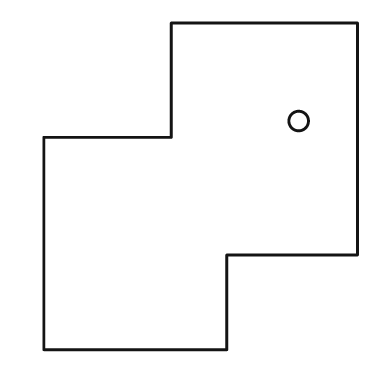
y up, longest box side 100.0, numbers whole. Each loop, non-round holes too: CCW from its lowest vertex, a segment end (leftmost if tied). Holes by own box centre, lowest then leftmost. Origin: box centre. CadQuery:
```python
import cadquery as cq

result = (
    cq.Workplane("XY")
    .moveTo(-48.0, -50.0)
    .lineTo(8.0, -50.0)
    .lineTo(8.0, -21.0)
    .lineTo(48.0, -21.0)
    .lineTo(48.0, 50.0)
    .lineTo(-9.0, 50.0)
    .lineTo(-9.0, 15.0)
    .lineTo(-48.0, 15.0)
    .close()
    .moveTo(30.0, 20.0)
    .circle(3.0)
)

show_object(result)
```